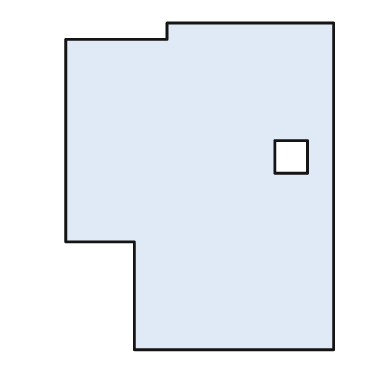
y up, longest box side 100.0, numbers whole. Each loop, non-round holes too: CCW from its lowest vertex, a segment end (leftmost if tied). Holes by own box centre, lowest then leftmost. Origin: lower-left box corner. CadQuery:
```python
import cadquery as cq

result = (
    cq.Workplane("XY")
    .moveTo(21.0, 0.0)
    .lineTo(82.0, 0.0)
    .lineTo(82.0, 100.0)
    .lineTo(31.0, 100.0)
    .lineTo(31.0, 95.0)
    .lineTo(0.0, 95.0)
    .lineTo(0.0, 33.0)
    .lineTo(21.0, 33.0)
    .close()
    .moveTo(64.0, 54.0)
    .lineTo(74.0, 54.0)
    .lineTo(74.0, 64.0)
    .lineTo(64.0, 64.0)
    .close()
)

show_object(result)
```